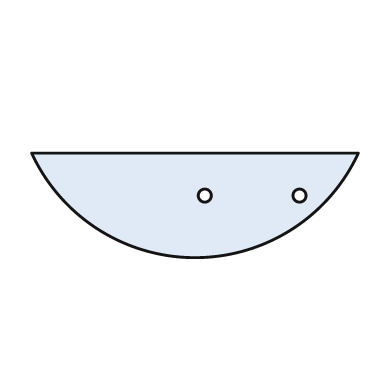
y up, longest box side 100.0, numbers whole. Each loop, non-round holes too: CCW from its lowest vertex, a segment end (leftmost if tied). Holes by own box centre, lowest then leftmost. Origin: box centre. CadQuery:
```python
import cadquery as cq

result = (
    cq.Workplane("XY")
    .moveTo(-50.0, 16.0)
    .threePointArc((0.0, -16.0), (50.0, 16.0))
    .close()
    .moveTo(3.0, 3.0)
    .circle(2.0)
    .moveTo(32.0, 3.0)
    .circle(2.0)
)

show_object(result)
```